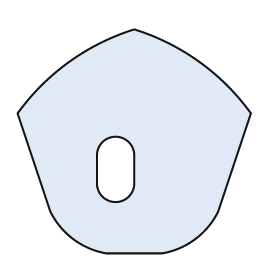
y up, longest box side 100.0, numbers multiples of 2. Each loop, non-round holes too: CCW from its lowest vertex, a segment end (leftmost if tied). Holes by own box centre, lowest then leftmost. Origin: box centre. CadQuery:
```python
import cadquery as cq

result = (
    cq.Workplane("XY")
    .moveTo(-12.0, -48.0)
    .lineTo(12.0, -48.0)
    .threePointArc((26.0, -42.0), (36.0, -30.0))
    .lineTo(50.0, 12.0)
    .threePointArc((28.0, 34.0), (0.0, 48.0))
    .threePointArc((-28.0, 34.0), (-50.0, 12.0))
    .lineTo(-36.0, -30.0)
    .threePointArc((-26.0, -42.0), (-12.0, -48.0))
    .close()
    .moveTo(-16.0, -18.0)
    .threePointArc((-8.0, -26.0), (0.0, -18.0))
    .lineTo(0.0, -6.0)
    .threePointArc((-8.0, 2.0), (-16.0, -6.0))
    .close()
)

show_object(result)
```